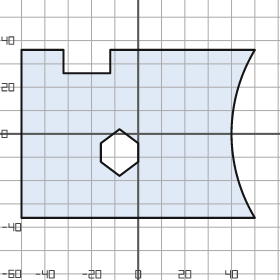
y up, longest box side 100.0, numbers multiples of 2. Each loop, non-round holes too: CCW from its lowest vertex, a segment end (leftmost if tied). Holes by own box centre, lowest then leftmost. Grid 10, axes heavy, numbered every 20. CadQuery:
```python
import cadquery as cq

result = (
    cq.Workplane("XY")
    .moveTo(-50.0, -36.0)
    .lineTo(50.0, -36.0)
    .threePointArc((40.0, 0.0), (50.0, 36.0))
    .lineTo(-12.0, 36.0)
    .lineTo(-12.0, 26.0)
    .lineTo(-32.0, 26.0)
    .lineTo(-32.0, 36.0)
    .lineTo(-50.0, 36.0)
    .close()
    .moveTo(-8.0, -18.0)
    .lineTo(0.0, -12.0)
    .lineTo(0.0, -4.0)
    .lineTo(-8.0, 2.0)
    .lineTo(-16.0, -4.0)
    .lineTo(-16.0, -12.0)
    .close()
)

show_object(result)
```